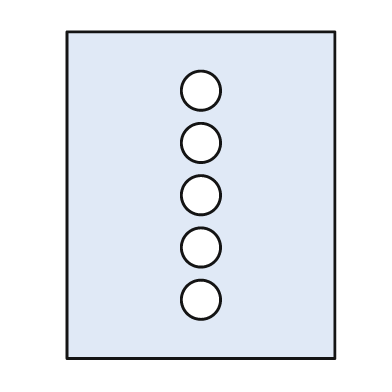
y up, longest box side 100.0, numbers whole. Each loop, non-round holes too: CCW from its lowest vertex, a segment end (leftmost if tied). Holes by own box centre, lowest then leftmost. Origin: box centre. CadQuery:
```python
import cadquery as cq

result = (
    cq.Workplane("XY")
    .moveTo(-41.0, -50.0)
    .lineTo(41.0, -50.0)
    .lineTo(41.0, 50.0)
    .lineTo(-41.0, 50.0)
    .close()
    .moveTo(0.0, -32.0)
    .circle(6.0)
    .moveTo(0.0, -16.0)
    .circle(6.0)
    .moveTo(0.0, 0.0)
    .circle(6.0)
    .moveTo(0.0, 16.0)
    .circle(6.0)
    .moveTo(0.0, 32.0)
    .circle(6.0)
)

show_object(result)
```